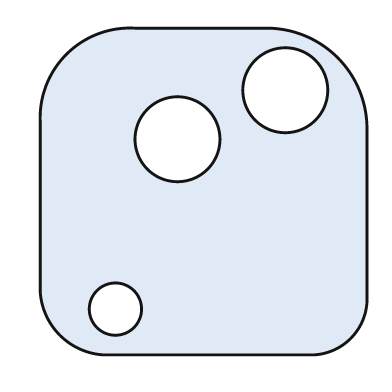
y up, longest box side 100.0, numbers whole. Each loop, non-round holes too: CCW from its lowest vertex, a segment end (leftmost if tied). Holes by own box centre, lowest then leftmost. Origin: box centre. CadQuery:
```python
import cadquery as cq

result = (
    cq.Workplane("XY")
    .moveTo(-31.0, -50.0)
    .lineTo(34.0, -50.0)
    .threePointArc((45.0, -45.0), (50.0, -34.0))
    .lineTo(50.0, 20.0)
    .threePointArc((41.0, 41.0), (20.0, 50.0))
    .lineTo(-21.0, 50.0)
    .threePointArc((-42.0, 42.0), (-50.0, 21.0))
    .lineTo(-50.0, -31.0)
    .threePointArc((-44.0, -44.0), (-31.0, -50.0))
    .close()
    .moveTo(-27.0, -36.0)
    .circle(8.0)
    .moveTo(-8.0, 16.0)
    .circle(13.0)
    .moveTo(25.0, 31.0)
    .circle(13.0)
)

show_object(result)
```